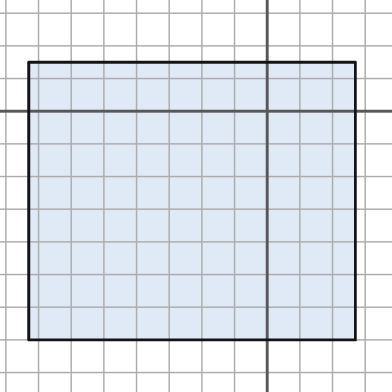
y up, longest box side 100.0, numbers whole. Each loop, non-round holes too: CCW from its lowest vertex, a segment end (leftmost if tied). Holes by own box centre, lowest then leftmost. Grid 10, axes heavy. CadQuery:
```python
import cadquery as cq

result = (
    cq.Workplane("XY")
    .moveTo(-73.0, -70.0)
    .lineTo(27.0, -70.0)
    .lineTo(27.0, 15.0)
    .lineTo(-73.0, 15.0)
    .close()
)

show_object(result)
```